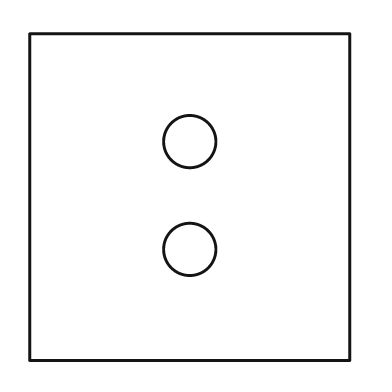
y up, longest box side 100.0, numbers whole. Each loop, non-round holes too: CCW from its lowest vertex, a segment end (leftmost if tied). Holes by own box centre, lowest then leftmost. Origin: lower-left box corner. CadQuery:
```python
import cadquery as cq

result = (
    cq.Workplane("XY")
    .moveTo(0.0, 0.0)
    .lineTo(98.0, 0.0)
    .lineTo(98.0, 100.0)
    .lineTo(0.0, 100.0)
    .close()
    .moveTo(49.0, 34.0)
    .circle(8.0)
    .moveTo(49.0, 67.0)
    .circle(8.0)
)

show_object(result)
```